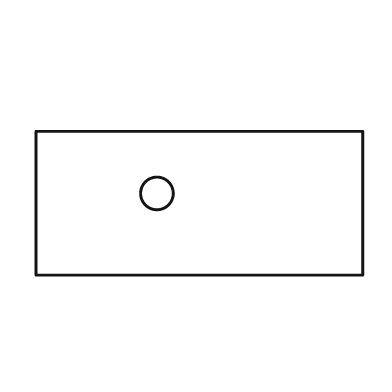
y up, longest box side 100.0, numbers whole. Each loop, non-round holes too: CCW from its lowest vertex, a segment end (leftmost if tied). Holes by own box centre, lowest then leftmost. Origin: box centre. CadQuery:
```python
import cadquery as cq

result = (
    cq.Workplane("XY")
    .moveTo(-50.0, -22.0)
    .lineTo(50.0, -22.0)
    .lineTo(50.0, 22.0)
    .lineTo(-50.0, 22.0)
    .close()
    .moveTo(-13.0, 3.0)
    .circle(5.0)
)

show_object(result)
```